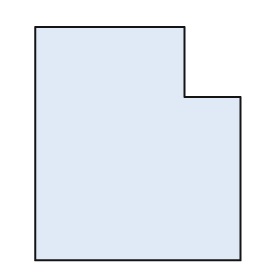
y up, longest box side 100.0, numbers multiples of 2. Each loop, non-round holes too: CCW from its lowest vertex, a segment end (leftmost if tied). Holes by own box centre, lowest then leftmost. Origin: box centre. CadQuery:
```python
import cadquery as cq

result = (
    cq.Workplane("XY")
    .moveTo(-44.0, -50.0)
    .lineTo(44.0, -50.0)
    .lineTo(44.0, 20.0)
    .lineTo(20.0, 20.0)
    .lineTo(20.0, 50.0)
    .lineTo(-44.0, 50.0)
    .close()
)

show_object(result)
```